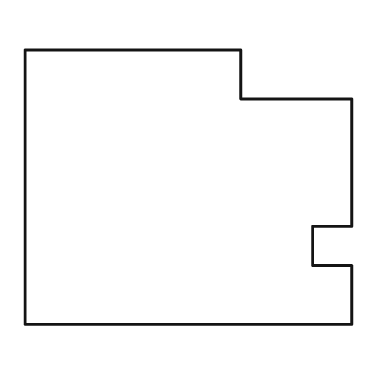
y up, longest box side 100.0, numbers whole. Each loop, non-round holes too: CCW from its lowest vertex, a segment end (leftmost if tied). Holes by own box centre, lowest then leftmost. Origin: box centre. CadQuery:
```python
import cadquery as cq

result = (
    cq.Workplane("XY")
    .moveTo(-50.0, -42.0)
    .lineTo(50.0, -42.0)
    .lineTo(50.0, -24.0)
    .lineTo(38.0, -24.0)
    .lineTo(38.0, -12.0)
    .lineTo(50.0, -12.0)
    .lineTo(50.0, 27.0)
    .lineTo(16.0, 27.0)
    .lineTo(16.0, 42.0)
    .lineTo(-50.0, 42.0)
    .close()
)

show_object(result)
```